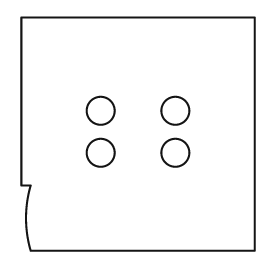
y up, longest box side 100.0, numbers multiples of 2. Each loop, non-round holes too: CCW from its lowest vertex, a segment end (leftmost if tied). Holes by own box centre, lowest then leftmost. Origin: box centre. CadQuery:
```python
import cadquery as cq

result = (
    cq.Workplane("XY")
    .moveTo(-46.0, -50.0)
    .lineTo(50.0, -50.0)
    .lineTo(50.0, 50.0)
    .lineTo(-50.0, 50.0)
    .lineTo(-50.0, -22.0)
    .lineTo(-46.0, -22.0)
    .threePointArc((-48.0, -36.0), (-46.0, -50.0))
    .close()
    .moveTo(-16.0, -8.0)
    .circle(6.0)
    .moveTo(16.0, -8.0)
    .circle(6.0)
    .moveTo(-16.0, 10.0)
    .circle(6.0)
    .moveTo(16.0, 10.0)
    .circle(6.0)
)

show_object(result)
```